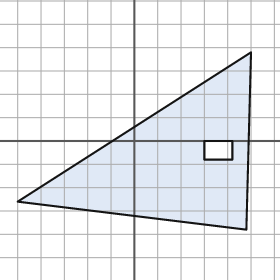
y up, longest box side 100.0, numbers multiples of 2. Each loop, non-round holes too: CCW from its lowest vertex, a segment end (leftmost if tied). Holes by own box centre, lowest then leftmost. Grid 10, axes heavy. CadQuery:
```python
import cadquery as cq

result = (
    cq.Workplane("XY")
    .moveTo(48.0, -38.0)
    .lineTo(50.0, 38.0)
    .lineTo(-50.0, -26.0)
    .close()
    .moveTo(30.0, -8.0)
    .lineTo(42.0, -8.0)
    .lineTo(42.0, 0.0)
    .lineTo(30.0, 0.0)
    .close()
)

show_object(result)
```